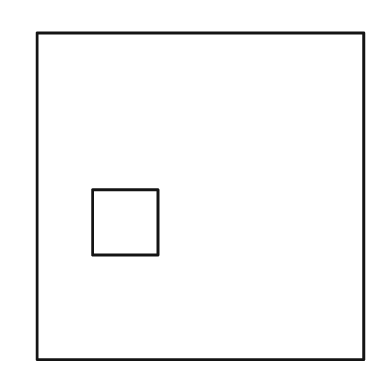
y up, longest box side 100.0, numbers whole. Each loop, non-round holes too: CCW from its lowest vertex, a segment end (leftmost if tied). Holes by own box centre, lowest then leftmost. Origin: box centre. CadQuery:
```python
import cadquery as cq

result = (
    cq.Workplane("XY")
    .moveTo(-50.0, -50.0)
    .lineTo(50.0, -50.0)
    .lineTo(50.0, 50.0)
    .lineTo(-50.0, 50.0)
    .close()
    .moveTo(-33.0, -18.0)
    .lineTo(-13.0, -18.0)
    .lineTo(-13.0, 2.0)
    .lineTo(-33.0, 2.0)
    .close()
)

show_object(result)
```